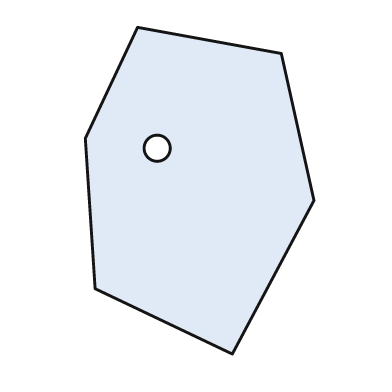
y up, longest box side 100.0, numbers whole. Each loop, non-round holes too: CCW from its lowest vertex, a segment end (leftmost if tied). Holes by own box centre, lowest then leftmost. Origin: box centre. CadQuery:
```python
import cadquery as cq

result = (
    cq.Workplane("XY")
    .moveTo(10.0, -50.0)
    .lineTo(35.0, -3.0)
    .lineTo(25.0, 42.0)
    .lineTo(-19.0, 50.0)
    .lineTo(-35.0, 16.0)
    .lineTo(-32.0, -30.0)
    .close()
    .moveTo(-13.0, 13.0)
    .circle(4.0)
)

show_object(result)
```